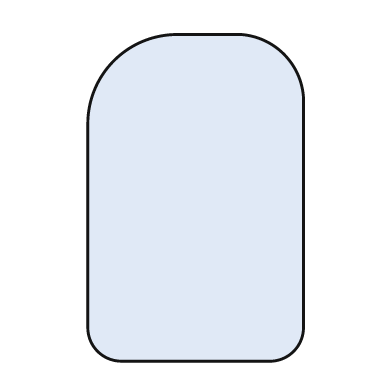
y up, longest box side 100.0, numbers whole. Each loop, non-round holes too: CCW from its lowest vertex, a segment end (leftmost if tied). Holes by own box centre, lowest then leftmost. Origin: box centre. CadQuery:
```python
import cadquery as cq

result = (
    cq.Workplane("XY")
    .moveTo(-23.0, -50.0)
    .lineTo(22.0, -50.0)
    .threePointArc((30.0, -47.0), (33.0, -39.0))
    .lineTo(33.0, 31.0)
    .threePointArc((27.0, 44.0), (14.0, 50.0))
    .lineTo(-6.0, 50.0)
    .threePointArc((-25.0, 42.0), (-33.0, 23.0))
    .lineTo(-33.0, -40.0)
    .threePointArc((-30.0, -47.0), (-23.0, -50.0))
    .close()
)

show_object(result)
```